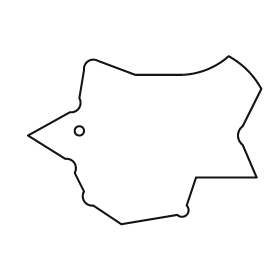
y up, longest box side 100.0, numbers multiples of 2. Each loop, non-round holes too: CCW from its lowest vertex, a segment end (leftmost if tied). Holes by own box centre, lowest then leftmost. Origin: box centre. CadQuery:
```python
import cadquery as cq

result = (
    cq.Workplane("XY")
    .moveTo(-10.0, -36.0)
    .lineTo(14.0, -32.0)
    .threePointArc((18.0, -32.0), (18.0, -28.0))
    .lineTo(22.0, -16.0)
    .lineTo(48.0, -16.0)
    .lineTo(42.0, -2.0)
    .threePointArc((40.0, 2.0), (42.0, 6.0))
    .lineTo(50.0, 22.0)
    .threePointArc((44.0, 30.0), (36.0, 36.0))
    .threePointArc((26.0, 30.0), (14.0, 28.0))
    .lineTo(-4.0, 28.0)
    .lineTo(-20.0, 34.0)
    .threePointArc((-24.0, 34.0), (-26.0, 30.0))
    .lineTo(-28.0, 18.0)
    .threePointArc((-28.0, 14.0), (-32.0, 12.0))
    .lineTo(-50.0, 2.0)
    .lineTo(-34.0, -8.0)
    .threePointArc((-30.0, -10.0), (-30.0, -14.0))
    .lineTo(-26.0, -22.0)
    .threePointArc((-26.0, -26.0), (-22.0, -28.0))
    .close()
    .moveTo(-28.0, 4.0)
    .circle(2.0)
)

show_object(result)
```